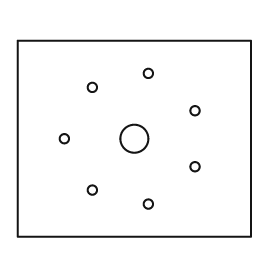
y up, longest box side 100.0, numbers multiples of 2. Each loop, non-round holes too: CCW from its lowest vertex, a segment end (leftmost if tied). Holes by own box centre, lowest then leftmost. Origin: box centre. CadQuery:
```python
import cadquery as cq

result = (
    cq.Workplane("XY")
    .moveTo(-50.0, -42.0)
    .lineTo(50.0, -42.0)
    .lineTo(50.0, 42.0)
    .lineTo(-50.0, 42.0)
    .close()
    .moveTo(6.0, -28.0)
    .circle(2.0)
    .moveTo(-18.0, -22.0)
    .circle(2.0)
    .moveTo(26.0, -12.0)
    .circle(2.0)
    .moveTo(-30.0, 0.0)
    .circle(2.0)
    .moveTo(0.0, 0.0)
    .circle(6.0)
    .moveTo(26.0, 12.0)
    .circle(2.0)
    .moveTo(-18.0, 22.0)
    .circle(2.0)
    .moveTo(6.0, 28.0)
    .circle(2.0)
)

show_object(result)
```